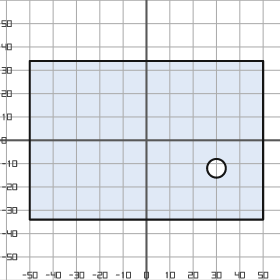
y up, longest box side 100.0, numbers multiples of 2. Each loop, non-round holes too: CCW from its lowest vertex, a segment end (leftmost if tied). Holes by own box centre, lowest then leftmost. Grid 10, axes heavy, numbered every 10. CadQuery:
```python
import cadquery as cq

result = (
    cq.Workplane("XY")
    .moveTo(-50.0, -34.0)
    .lineTo(50.0, -34.0)
    .lineTo(50.0, 34.0)
    .lineTo(-50.0, 34.0)
    .close()
    .moveTo(30.0, -12.0)
    .circle(4.0)
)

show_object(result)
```